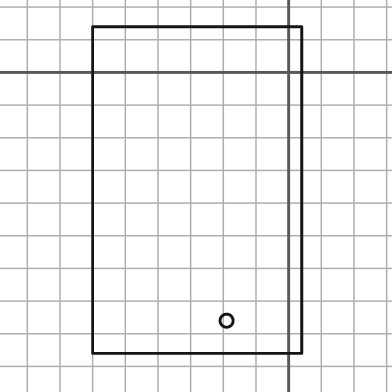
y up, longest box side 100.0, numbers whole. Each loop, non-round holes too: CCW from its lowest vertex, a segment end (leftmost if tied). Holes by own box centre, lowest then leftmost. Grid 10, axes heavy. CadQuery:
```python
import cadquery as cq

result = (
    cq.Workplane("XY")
    .moveTo(-60.0, -86.0)
    .lineTo(4.0, -86.0)
    .lineTo(4.0, 14.0)
    .lineTo(-60.0, 14.0)
    .close()
    .moveTo(-19.0, -76.0)
    .circle(2.0)
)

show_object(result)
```